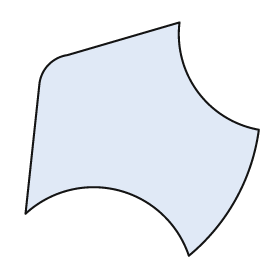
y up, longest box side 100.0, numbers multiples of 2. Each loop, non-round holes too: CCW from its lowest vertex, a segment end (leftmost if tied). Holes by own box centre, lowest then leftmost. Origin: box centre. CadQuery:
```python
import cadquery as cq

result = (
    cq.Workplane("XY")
    .moveTo(20.0, -50.0)
    .threePointArc((40.0, -26.0), (50.0, 4.0))
    .threePointArc((24.0, 20.0), (16.0, 50.0))
    .lineTo(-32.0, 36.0)
    .threePointArc((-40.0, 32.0), (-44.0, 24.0))
    .lineTo(-50.0, -32.0)
    .threePointArc((-10.0, -22.0), (20.0, -50.0))
    .close()
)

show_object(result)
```